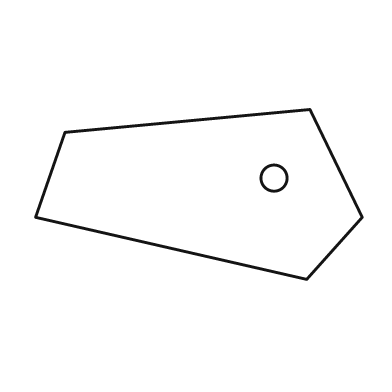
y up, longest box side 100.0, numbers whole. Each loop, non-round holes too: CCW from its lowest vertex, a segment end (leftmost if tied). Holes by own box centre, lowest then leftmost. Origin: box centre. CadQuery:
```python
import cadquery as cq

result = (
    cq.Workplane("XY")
    .moveTo(33.0, -26.0)
    .lineTo(50.0, -7.0)
    .lineTo(34.0, 26.0)
    .lineTo(-41.0, 19.0)
    .lineTo(-50.0, -7.0)
    .close()
    .moveTo(23.0, 5.0)
    .circle(4.0)
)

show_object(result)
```